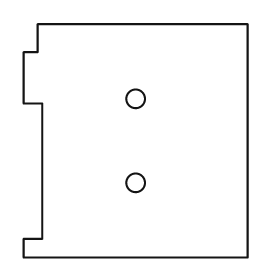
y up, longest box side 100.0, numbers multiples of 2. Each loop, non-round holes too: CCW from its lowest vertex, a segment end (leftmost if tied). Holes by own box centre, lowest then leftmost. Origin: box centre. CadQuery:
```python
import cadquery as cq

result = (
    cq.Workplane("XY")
    .moveTo(-48.0, -50.0)
    .lineTo(48.0, -50.0)
    .lineTo(48.0, 50.0)
    .lineTo(-42.0, 50.0)
    .lineTo(-42.0, 38.0)
    .lineTo(-48.0, 38.0)
    .lineTo(-48.0, 16.0)
    .lineTo(-40.0, 16.0)
    .lineTo(-40.0, -42.0)
    .lineTo(-48.0, -42.0)
    .close()
    .moveTo(0.0, -18.0)
    .circle(4.0)
    .moveTo(0.0, 18.0)
    .circle(4.0)
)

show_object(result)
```